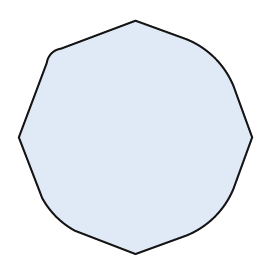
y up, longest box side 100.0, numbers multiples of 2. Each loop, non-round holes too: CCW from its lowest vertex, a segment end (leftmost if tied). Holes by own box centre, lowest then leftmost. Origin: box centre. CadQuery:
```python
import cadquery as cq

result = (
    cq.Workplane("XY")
    .moveTo(0.0, -50.0)
    .lineTo(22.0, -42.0)
    .threePointArc((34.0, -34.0), (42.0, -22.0))
    .lineTo(50.0, 0.0)
    .lineTo(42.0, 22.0)
    .threePointArc((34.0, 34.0), (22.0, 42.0))
    .lineTo(0.0, 50.0)
    .lineTo(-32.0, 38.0)
    .threePointArc((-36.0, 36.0), (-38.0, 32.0))
    .lineTo(-50.0, 0.0)
    .lineTo(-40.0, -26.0)
    .threePointArc((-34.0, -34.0), (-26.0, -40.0))
    .close()
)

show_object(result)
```